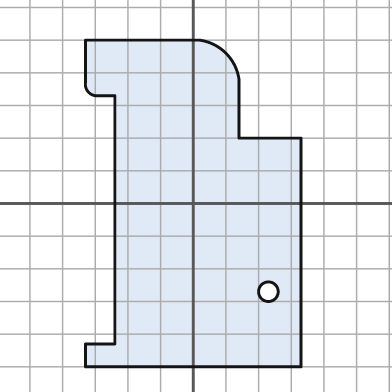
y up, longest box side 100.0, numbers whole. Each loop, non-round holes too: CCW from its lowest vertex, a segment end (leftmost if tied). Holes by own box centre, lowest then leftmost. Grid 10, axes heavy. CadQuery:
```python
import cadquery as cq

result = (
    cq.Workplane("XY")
    .moveTo(-33.0, -50.0)
    .lineTo(33.0, -50.0)
    .lineTo(33.0, 20.0)
    .lineTo(14.0, 20.0)
    .lineTo(14.0, 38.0)
    .threePointArc((10.0, 46.0), (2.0, 50.0))
    .lineTo(-33.0, 50.0)
    .lineTo(-33.0, 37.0)
    .threePointArc((-32.0, 34.0), (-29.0, 33.0))
    .lineTo(-24.0, 33.0)
    .lineTo(-24.0, -43.0)
    .lineTo(-33.0, -43.0)
    .close()
    .moveTo(23.0, -27.0)
    .circle(3.0)
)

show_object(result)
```